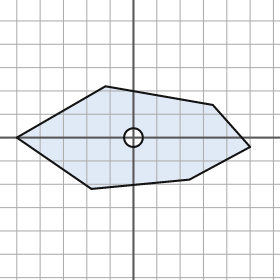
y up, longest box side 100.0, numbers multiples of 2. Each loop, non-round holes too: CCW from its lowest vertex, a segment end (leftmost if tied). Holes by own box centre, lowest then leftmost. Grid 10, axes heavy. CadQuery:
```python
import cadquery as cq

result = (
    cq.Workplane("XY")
    .moveTo(-18.0, -22.0)
    .lineTo(24.0, -18.0)
    .lineTo(50.0, -4.0)
    .lineTo(34.0, 14.0)
    .lineTo(-12.0, 22.0)
    .lineTo(-50.0, 0.0)
    .close()
    .moveTo(0.0, 0.0)
    .circle(4.0)
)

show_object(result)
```